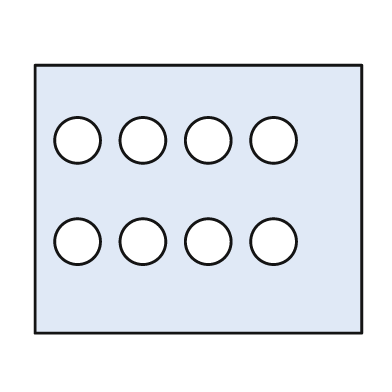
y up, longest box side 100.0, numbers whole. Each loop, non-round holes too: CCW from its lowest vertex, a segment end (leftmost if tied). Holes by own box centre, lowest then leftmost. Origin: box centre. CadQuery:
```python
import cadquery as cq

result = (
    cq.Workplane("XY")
    .moveTo(-50.0, -41.0)
    .lineTo(50.0, -41.0)
    .lineTo(50.0, 41.0)
    .lineTo(-50.0, 41.0)
    .close()
    .moveTo(-37.0, -13.0)
    .circle(7.0)
    .moveTo(-17.0, -13.0)
    .circle(7.0)
    .moveTo(3.0, -13.0)
    .circle(7.0)
    .moveTo(23.0, -13.0)
    .circle(7.0)
    .moveTo(-37.0, 18.0)
    .circle(7.0)
    .moveTo(-17.0, 18.0)
    .circle(7.0)
    .moveTo(3.0, 18.0)
    .circle(7.0)
    .moveTo(23.0, 18.0)
    .circle(7.0)
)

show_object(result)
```